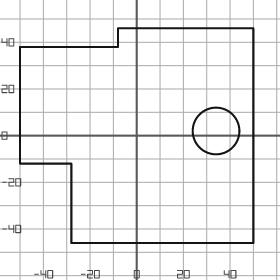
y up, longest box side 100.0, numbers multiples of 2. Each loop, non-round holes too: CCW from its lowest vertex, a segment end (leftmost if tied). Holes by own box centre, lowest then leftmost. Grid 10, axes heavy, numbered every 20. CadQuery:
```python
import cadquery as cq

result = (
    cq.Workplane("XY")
    .moveTo(-28.0, -46.0)
    .lineTo(50.0, -46.0)
    .lineTo(50.0, 46.0)
    .lineTo(-8.0, 46.0)
    .lineTo(-8.0, 38.0)
    .lineTo(-50.0, 38.0)
    .lineTo(-50.0, -12.0)
    .lineTo(-28.0, -12.0)
    .close()
    .moveTo(34.0, 2.0)
    .circle(10.0)
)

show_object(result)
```